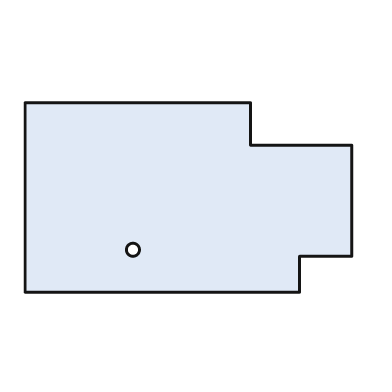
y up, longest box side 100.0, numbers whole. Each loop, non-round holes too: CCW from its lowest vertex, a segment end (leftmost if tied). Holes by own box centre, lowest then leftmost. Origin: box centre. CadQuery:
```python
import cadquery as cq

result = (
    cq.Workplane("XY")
    .moveTo(-50.0, -29.0)
    .lineTo(34.0, -29.0)
    .lineTo(34.0, -18.0)
    .lineTo(50.0, -18.0)
    .lineTo(50.0, 16.0)
    .lineTo(19.0, 16.0)
    .lineTo(19.0, 29.0)
    .lineTo(-50.0, 29.0)
    .close()
    .moveTo(-17.0, -16.0)
    .circle(2.0)
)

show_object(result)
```